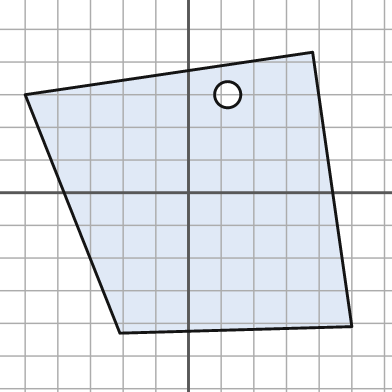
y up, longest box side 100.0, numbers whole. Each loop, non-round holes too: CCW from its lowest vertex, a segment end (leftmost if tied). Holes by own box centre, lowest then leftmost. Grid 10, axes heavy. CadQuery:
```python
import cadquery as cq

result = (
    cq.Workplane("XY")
    .moveTo(-21.0, -43.0)
    .lineTo(50.0, -41.0)
    .lineTo(38.0, 43.0)
    .lineTo(-50.0, 30.0)
    .close()
    .moveTo(12.0, 30.0)
    .circle(4.0)
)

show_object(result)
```